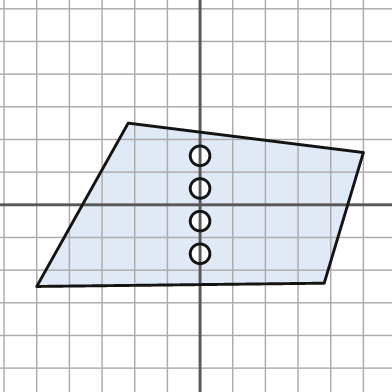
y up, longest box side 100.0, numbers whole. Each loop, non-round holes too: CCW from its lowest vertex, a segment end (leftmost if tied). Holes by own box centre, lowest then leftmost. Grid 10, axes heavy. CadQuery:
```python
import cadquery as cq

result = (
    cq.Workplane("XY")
    .moveTo(-50.0, -25.0)
    .lineTo(38.0, -24.0)
    .lineTo(50.0, 16.0)
    .lineTo(-22.0, 25.0)
    .close()
    .moveTo(0.0, -15.0)
    .circle(3.0)
    .moveTo(0.0, -5.0)
    .circle(3.0)
    .moveTo(0.0, 5.0)
    .circle(3.0)
    .moveTo(0.0, 15.0)
    .circle(3.0)
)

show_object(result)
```